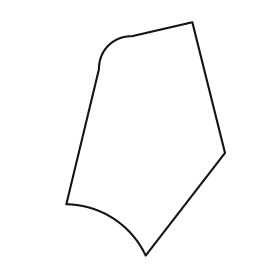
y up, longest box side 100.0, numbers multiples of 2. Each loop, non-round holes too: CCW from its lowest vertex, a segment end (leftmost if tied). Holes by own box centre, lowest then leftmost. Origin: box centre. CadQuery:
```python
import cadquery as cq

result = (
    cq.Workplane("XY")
    .moveTo(0.0, -50.0)
    .lineTo(34.0, -6.0)
    .lineTo(20.0, 50.0)
    .lineTo(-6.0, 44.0)
    .threePointArc((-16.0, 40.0), (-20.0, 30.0))
    .lineTo(-34.0, -28.0)
    .threePointArc((-14.0, -34.0), (0.0, -50.0))
    .close()
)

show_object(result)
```